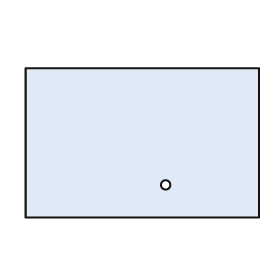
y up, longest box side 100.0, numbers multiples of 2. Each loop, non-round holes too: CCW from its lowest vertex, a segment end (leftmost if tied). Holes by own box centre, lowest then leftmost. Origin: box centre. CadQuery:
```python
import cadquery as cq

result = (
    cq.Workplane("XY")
    .moveTo(-50.0, -32.0)
    .lineTo(50.0, -32.0)
    .lineTo(50.0, 32.0)
    .lineTo(-50.0, 32.0)
    .close()
    .moveTo(10.0, -18.0)
    .circle(2.0)
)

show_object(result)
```